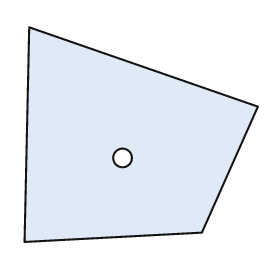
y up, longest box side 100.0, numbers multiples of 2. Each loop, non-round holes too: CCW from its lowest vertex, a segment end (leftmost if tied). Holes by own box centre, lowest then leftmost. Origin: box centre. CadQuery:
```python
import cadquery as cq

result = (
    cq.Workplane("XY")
    .moveTo(-50.0, -46.0)
    .lineTo(26.0, -42.0)
    .lineTo(50.0, 12.0)
    .lineTo(-48.0, 46.0)
    .close()
    .moveTo(-8.0, -10.0)
    .circle(4.0)
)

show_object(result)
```